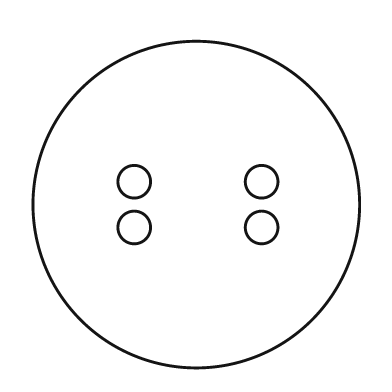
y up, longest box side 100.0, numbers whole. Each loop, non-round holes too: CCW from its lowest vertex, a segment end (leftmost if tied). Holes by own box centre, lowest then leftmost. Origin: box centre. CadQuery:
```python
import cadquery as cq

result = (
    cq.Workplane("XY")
    .moveTo(0.0, 0.0)
    .circle(50.0)
    .moveTo(-19.0, -7.0)
    .circle(5.0)
    .moveTo(20.0, -7.0)
    .circle(5.0)
    .moveTo(-19.0, 7.0)
    .circle(5.0)
    .moveTo(20.0, 7.0)
    .circle(5.0)
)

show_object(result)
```